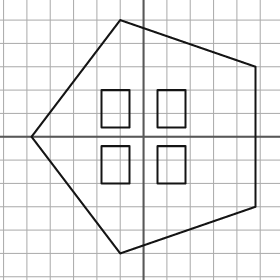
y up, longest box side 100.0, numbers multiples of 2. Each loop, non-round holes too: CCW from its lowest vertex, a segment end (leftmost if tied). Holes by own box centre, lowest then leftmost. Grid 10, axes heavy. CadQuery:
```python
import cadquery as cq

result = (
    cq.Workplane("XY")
    .moveTo(-10.0, -50.0)
    .lineTo(48.0, -30.0)
    .lineTo(48.0, 30.0)
    .lineTo(-10.0, 50.0)
    .lineTo(-48.0, 0.0)
    .close()
    .moveTo(-18.0, -20.0)
    .lineTo(-6.0, -20.0)
    .lineTo(-6.0, -4.0)
    .lineTo(-18.0, -4.0)
    .close()
    .moveTo(6.0, -20.0)
    .lineTo(18.0, -20.0)
    .lineTo(18.0, -4.0)
    .lineTo(6.0, -4.0)
    .close()
    .moveTo(-18.0, 4.0)
    .lineTo(-6.0, 4.0)
    .lineTo(-6.0, 20.0)
    .lineTo(-18.0, 20.0)
    .close()
    .moveTo(6.0, 4.0)
    .lineTo(18.0, 4.0)
    .lineTo(18.0, 20.0)
    .lineTo(6.0, 20.0)
    .close()
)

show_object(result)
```